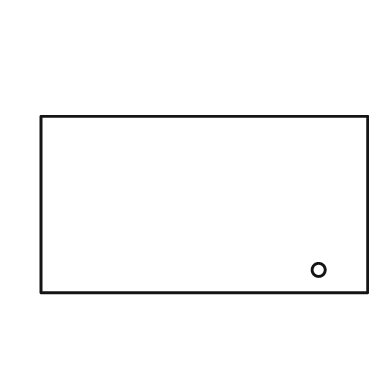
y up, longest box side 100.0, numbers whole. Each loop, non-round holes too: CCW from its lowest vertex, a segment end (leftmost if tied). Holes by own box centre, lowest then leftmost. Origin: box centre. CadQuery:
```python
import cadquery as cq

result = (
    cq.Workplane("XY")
    .moveTo(-50.0, -27.0)
    .lineTo(50.0, -27.0)
    .lineTo(50.0, 27.0)
    .lineTo(-50.0, 27.0)
    .close()
    .moveTo(35.0, -20.0)
    .circle(2.0)
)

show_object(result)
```